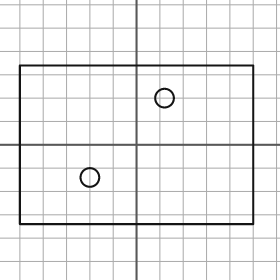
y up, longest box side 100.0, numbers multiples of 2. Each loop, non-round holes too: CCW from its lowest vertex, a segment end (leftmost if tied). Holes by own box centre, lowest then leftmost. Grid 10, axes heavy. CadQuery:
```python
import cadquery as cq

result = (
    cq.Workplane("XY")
    .moveTo(-50.0, -34.0)
    .lineTo(50.0, -34.0)
    .lineTo(50.0, 34.0)
    .lineTo(-50.0, 34.0)
    .close()
    .moveTo(-20.0, -14.0)
    .circle(4.0)
    .moveTo(12.0, 20.0)
    .circle(4.0)
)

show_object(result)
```